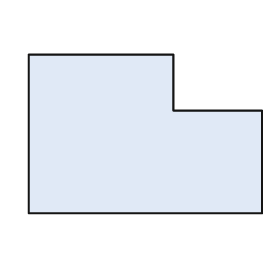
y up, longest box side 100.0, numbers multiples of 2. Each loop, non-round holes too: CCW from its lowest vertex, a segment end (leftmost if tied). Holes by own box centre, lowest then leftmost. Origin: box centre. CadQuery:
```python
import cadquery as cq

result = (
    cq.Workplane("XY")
    .moveTo(-50.0, -34.0)
    .lineTo(50.0, -34.0)
    .lineTo(50.0, 10.0)
    .lineTo(12.0, 10.0)
    .lineTo(12.0, 34.0)
    .lineTo(-50.0, 34.0)
    .close()
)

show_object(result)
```